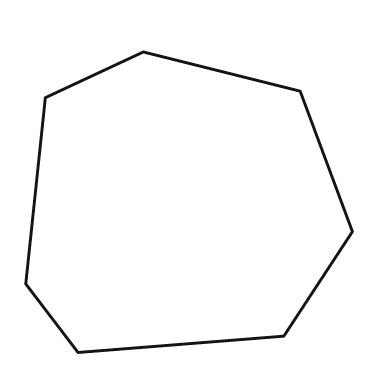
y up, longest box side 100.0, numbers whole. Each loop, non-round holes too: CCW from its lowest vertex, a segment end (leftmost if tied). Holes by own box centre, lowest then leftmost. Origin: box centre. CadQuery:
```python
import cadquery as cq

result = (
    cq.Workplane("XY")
    .moveTo(-34.0, -46.0)
    .lineTo(29.0, -41.0)
    .lineTo(50.0, -9.0)
    .lineTo(34.0, 34.0)
    .lineTo(-14.0, 46.0)
    .lineTo(-44.0, 32.0)
    .lineTo(-50.0, -25.0)
    .close()
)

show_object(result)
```